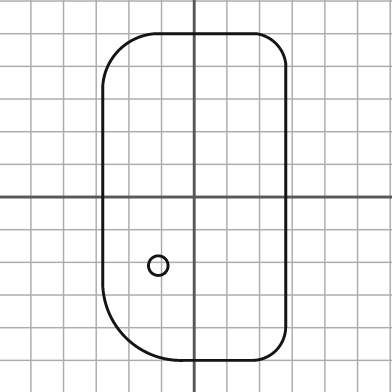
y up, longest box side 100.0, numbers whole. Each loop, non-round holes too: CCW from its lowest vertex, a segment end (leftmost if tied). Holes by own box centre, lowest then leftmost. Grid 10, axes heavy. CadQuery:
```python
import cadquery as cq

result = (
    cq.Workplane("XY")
    .moveTo(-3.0, -50.0)
    .lineTo(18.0, -50.0)
    .threePointArc((25.0, -47.0), (28.0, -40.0))
    .lineTo(28.0, 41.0)
    .threePointArc((25.0, 47.0), (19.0, 50.0))
    .lineTo(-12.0, 50.0)
    .threePointArc((-23.0, 45.0), (-28.0, 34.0))
    .lineTo(-28.0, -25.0)
    .threePointArc((-21.0, -43.0), (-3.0, -50.0))
    .close()
    .moveTo(-11.0, -21.0)
    .circle(3.0)
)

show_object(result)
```